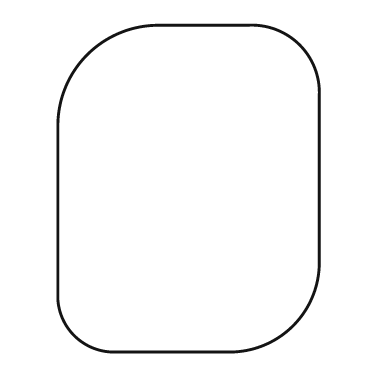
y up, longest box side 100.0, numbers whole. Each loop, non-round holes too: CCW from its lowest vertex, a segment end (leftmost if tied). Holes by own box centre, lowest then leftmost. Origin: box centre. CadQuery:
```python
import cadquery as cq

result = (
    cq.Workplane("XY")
    .moveTo(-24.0, -50.0)
    .lineTo(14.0, -50.0)
    .threePointArc((32.0, -42.0), (40.0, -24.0))
    .lineTo(40.0, 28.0)
    .threePointArc((34.0, 44.0), (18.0, 50.0))
    .lineTo(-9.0, 50.0)
    .threePointArc((-31.0, 41.0), (-40.0, 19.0))
    .lineTo(-40.0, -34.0)
    .threePointArc((-35.0, -45.0), (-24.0, -50.0))
    .close()
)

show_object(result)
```